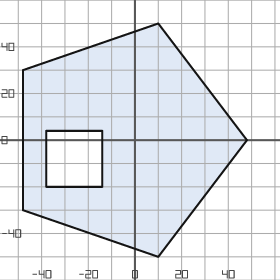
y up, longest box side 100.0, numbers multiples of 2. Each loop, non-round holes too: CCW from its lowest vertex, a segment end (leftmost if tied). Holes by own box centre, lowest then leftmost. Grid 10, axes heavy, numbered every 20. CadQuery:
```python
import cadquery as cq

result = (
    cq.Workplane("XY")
    .moveTo(10.0, -50.0)
    .lineTo(48.0, 0.0)
    .lineTo(10.0, 50.0)
    .lineTo(-48.0, 30.0)
    .lineTo(-48.0, -30.0)
    .close()
    .moveTo(-38.0, -20.0)
    .lineTo(-14.0, -20.0)
    .lineTo(-14.0, 4.0)
    .lineTo(-38.0, 4.0)
    .close()
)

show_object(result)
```